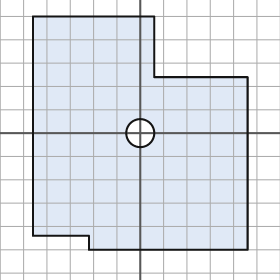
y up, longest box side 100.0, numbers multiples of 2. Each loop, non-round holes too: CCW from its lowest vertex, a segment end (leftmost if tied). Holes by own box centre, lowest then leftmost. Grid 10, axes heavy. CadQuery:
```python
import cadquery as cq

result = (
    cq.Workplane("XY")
    .moveTo(-22.0, -50.0)
    .lineTo(46.0, -50.0)
    .lineTo(46.0, 24.0)
    .lineTo(6.0, 24.0)
    .lineTo(6.0, 50.0)
    .lineTo(-46.0, 50.0)
    .lineTo(-46.0, -44.0)
    .lineTo(-22.0, -44.0)
    .close()
    .moveTo(0.0, 0.0)
    .circle(6.0)
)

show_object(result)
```